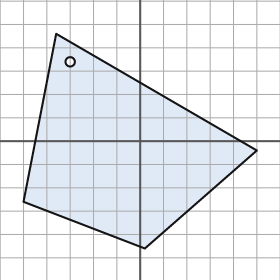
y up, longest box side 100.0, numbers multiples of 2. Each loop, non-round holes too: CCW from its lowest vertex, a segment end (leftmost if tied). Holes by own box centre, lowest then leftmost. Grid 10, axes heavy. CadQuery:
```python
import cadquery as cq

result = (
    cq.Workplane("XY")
    .moveTo(2.0, -46.0)
    .lineTo(50.0, -4.0)
    .lineTo(-36.0, 46.0)
    .lineTo(-50.0, -26.0)
    .close()
    .moveTo(-30.0, 34.0)
    .circle(2.0)
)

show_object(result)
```